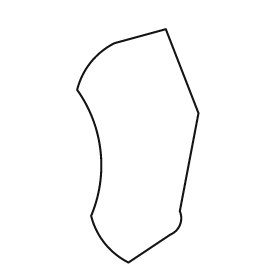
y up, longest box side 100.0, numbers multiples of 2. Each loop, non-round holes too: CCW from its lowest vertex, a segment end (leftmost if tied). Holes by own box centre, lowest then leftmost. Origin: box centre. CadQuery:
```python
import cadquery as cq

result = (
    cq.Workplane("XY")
    .moveTo(-4.0, -50.0)
    .lineTo(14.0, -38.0)
    .threePointArc((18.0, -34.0), (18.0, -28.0))
    .lineTo(26.0, 14.0)
    .lineTo(12.0, 50.0)
    .lineTo(-10.0, 44.0)
    .threePointArc((-20.0, 36.0), (-26.0, 24.0))
    .threePointArc((-16.0, -2.0), (-20.0, -30.0))
    .threePointArc((-14.0, -42.0), (-4.0, -50.0))
    .close()
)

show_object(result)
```